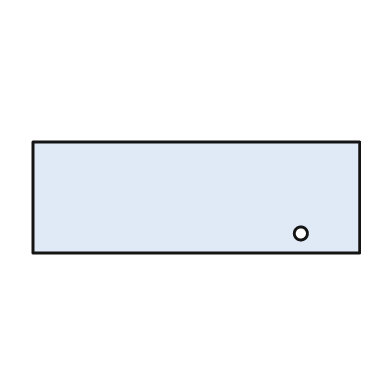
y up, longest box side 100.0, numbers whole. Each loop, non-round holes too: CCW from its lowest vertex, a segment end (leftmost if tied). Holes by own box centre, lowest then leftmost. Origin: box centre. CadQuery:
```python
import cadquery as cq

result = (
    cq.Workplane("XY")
    .moveTo(-50.0, -17.0)
    .lineTo(50.0, -17.0)
    .lineTo(50.0, 17.0)
    .lineTo(-50.0, 17.0)
    .close()
    .moveTo(32.0, -11.0)
    .circle(2.0)
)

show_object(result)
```